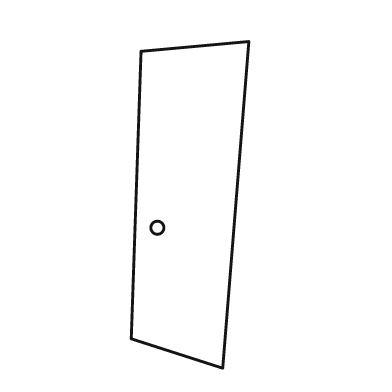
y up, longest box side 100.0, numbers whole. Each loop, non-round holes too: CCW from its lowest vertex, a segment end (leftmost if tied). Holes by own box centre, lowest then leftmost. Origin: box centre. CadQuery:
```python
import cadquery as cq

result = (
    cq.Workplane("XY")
    .moveTo(10.0, -50.0)
    .lineTo(18.0, 50.0)
    .lineTo(-15.0, 47.0)
    .lineTo(-18.0, -41.0)
    .close()
    .moveTo(-10.0, -7.0)
    .circle(2.0)
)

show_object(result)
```